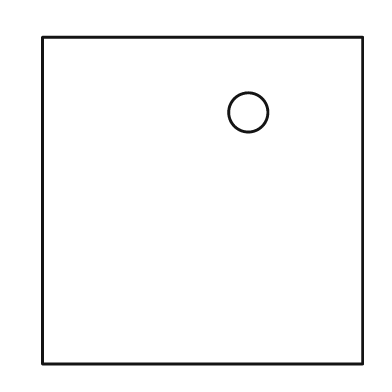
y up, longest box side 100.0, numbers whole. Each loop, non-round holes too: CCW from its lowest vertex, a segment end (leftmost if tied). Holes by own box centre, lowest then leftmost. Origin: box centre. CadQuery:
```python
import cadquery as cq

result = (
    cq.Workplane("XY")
    .moveTo(-49.0, -50.0)
    .lineTo(49.0, -50.0)
    .lineTo(49.0, 50.0)
    .lineTo(-49.0, 50.0)
    .close()
    .moveTo(14.0, 27.0)
    .circle(6.0)
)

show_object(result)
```